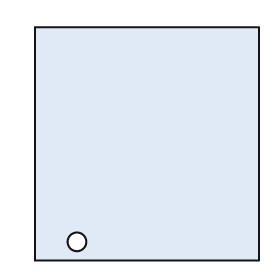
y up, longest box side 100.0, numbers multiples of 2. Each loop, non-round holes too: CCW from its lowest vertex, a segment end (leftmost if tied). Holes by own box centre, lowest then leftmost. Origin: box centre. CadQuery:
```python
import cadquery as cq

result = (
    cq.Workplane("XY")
    .moveTo(-48.0, -50.0)
    .lineTo(48.0, -50.0)
    .lineTo(48.0, 50.0)
    .lineTo(-48.0, 50.0)
    .close()
    .moveTo(-30.0, -42.0)
    .circle(4.0)
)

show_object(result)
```